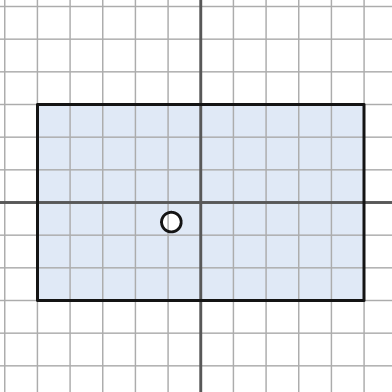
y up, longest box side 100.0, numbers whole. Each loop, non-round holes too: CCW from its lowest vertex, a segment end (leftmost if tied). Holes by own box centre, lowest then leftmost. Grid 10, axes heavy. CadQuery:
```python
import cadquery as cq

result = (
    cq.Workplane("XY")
    .moveTo(-50.0, -30.0)
    .lineTo(50.0, -30.0)
    .lineTo(50.0, 30.0)
    .lineTo(-50.0, 30.0)
    .close()
    .moveTo(-9.0, -6.0)
    .circle(3.0)
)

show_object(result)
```